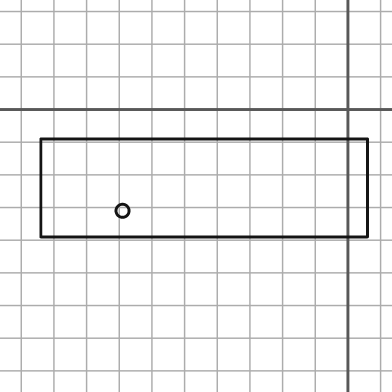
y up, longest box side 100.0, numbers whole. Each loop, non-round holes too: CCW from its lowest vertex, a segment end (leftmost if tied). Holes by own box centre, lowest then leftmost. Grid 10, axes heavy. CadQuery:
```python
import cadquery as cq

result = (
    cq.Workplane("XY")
    .moveTo(-94.0, -39.0)
    .lineTo(6.0, -39.0)
    .lineTo(6.0, -9.0)
    .lineTo(-94.0, -9.0)
    .close()
    .moveTo(-69.0, -31.0)
    .circle(2.0)
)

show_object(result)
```